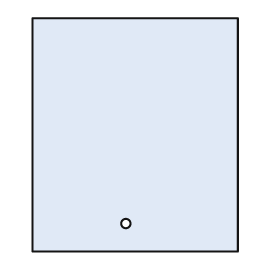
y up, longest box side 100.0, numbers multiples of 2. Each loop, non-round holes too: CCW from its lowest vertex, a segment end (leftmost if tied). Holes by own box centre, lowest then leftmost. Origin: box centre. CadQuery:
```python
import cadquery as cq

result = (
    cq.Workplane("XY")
    .moveTo(-44.0, -50.0)
    .lineTo(44.0, -50.0)
    .lineTo(44.0, 50.0)
    .lineTo(-44.0, 50.0)
    .close()
    .moveTo(-4.0, -38.0)
    .circle(2.0)
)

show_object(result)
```